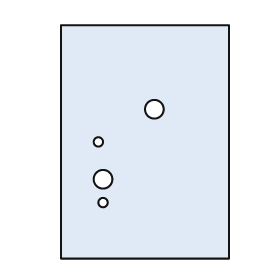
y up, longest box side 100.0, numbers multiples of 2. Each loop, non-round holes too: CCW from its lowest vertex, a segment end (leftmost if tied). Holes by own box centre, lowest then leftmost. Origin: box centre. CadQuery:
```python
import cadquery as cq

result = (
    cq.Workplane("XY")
    .moveTo(-36.0, -50.0)
    .lineTo(36.0, -50.0)
    .lineTo(36.0, 50.0)
    .lineTo(-36.0, 50.0)
    .close()
    .moveTo(-18.0, -26.0)
    .circle(2.0)
    .moveTo(-18.0, -16.0)
    .circle(4.0)
    .moveTo(-20.0, 0.0)
    .circle(2.0)
    .moveTo(4.0, 14.0)
    .circle(4.0)
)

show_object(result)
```